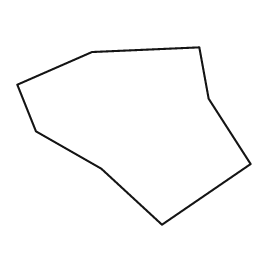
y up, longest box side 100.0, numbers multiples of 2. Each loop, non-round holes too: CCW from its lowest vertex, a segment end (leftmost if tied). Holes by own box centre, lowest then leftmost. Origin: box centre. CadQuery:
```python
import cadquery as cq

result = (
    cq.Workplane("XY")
    .moveTo(12.0, -38.0)
    .lineTo(50.0, -12.0)
    .lineTo(32.0, 16.0)
    .lineTo(28.0, 38.0)
    .lineTo(-18.0, 36.0)
    .lineTo(-50.0, 22.0)
    .lineTo(-42.0, 2.0)
    .lineTo(-14.0, -14.0)
    .close()
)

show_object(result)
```